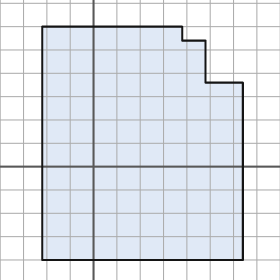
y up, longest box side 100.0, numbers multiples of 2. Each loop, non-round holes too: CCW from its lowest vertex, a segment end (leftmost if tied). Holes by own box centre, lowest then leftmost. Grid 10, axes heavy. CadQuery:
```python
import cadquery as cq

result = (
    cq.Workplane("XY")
    .moveTo(-22.0, -40.0)
    .lineTo(64.0, -40.0)
    .lineTo(64.0, 36.0)
    .lineTo(48.0, 36.0)
    .lineTo(48.0, 54.0)
    .lineTo(38.0, 54.0)
    .lineTo(38.0, 60.0)
    .lineTo(-22.0, 60.0)
    .close()
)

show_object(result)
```